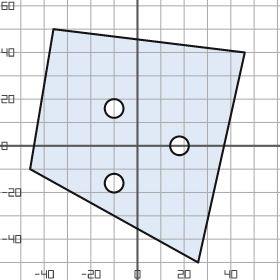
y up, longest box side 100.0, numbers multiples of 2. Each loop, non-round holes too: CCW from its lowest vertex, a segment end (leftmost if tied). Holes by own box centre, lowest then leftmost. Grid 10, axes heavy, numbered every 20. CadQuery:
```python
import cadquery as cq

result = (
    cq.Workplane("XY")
    .moveTo(26.0, -50.0)
    .lineTo(46.0, 40.0)
    .lineTo(-36.0, 50.0)
    .lineTo(-46.0, -10.0)
    .close()
    .moveTo(-10.0, -16.0)
    .circle(4.0)
    .moveTo(18.0, 0.0)
    .circle(4.0)
    .moveTo(-10.0, 16.0)
    .circle(4.0)
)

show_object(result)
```